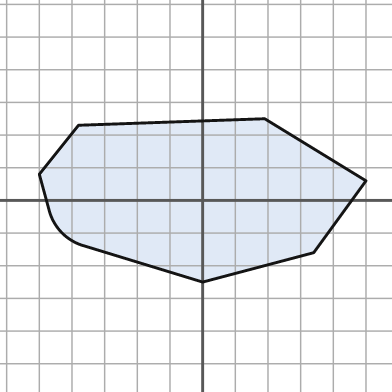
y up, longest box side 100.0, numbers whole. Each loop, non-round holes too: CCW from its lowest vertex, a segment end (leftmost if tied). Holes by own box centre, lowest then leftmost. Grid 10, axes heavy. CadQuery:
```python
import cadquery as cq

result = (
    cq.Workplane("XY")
    .moveTo(0.0, -25.0)
    .lineTo(34.0, -16.0)
    .lineTo(50.0, 6.0)
    .lineTo(19.0, 25.0)
    .lineTo(-38.0, 23.0)
    .lineTo(-50.0, 8.0)
    .lineTo(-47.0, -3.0)
    .threePointArc((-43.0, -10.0), (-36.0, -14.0))
    .close()
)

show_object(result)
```